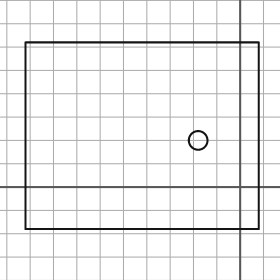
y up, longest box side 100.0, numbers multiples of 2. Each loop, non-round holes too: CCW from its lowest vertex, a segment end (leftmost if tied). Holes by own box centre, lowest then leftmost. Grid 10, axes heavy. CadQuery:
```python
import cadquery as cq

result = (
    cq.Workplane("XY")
    .moveTo(-92.0, -18.0)
    .lineTo(8.0, -18.0)
    .lineTo(8.0, 62.0)
    .lineTo(-92.0, 62.0)
    .close()
    .moveTo(-18.0, 20.0)
    .circle(4.0)
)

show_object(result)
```